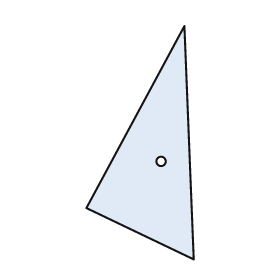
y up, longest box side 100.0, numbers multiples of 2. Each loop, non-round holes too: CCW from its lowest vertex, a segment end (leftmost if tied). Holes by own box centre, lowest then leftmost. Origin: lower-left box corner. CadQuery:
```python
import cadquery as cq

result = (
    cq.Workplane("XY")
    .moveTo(46.0, 0.0)
    .lineTo(42.0, 100.0)
    .lineTo(0.0, 22.0)
    .close()
    .moveTo(32.0, 42.0)
    .circle(2.0)
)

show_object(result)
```